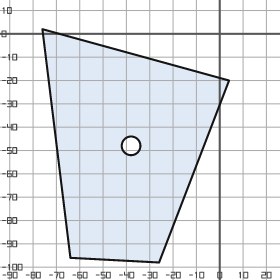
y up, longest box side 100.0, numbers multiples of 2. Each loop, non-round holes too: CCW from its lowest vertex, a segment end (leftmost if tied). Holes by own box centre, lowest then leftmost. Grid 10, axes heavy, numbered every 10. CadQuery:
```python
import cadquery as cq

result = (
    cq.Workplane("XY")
    .moveTo(-26.0, -98.0)
    .lineTo(4.0, -20.0)
    .lineTo(-76.0, 2.0)
    .lineTo(-64.0, -96.0)
    .close()
    .moveTo(-38.0, -48.0)
    .circle(4.0)
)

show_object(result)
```